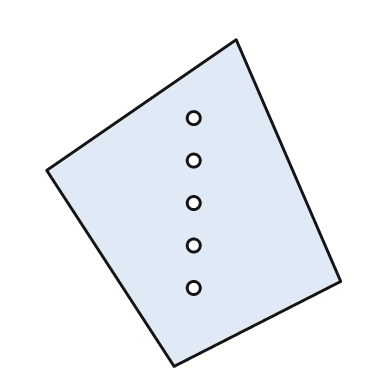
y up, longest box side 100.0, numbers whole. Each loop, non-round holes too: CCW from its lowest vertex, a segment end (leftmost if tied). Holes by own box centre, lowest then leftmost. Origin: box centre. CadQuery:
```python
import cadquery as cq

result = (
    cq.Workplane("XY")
    .moveTo(-6.0, -50.0)
    .lineTo(45.0, -24.0)
    .lineTo(13.0, 50.0)
    .lineTo(-45.0, 10.0)
    .close()
    .moveTo(0.0, -26.0)
    .circle(2.0)
    .moveTo(0.0, -13.0)
    .circle(2.0)
    .moveTo(0.0, 0.0)
    .circle(2.0)
    .moveTo(0.0, 13.0)
    .circle(2.0)
    .moveTo(0.0, 26.0)
    .circle(2.0)
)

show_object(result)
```